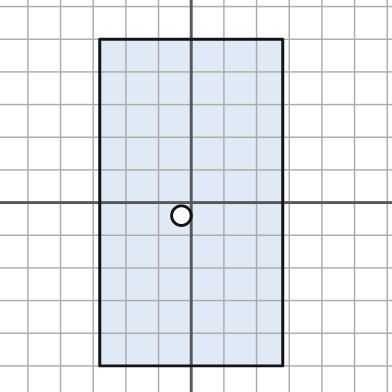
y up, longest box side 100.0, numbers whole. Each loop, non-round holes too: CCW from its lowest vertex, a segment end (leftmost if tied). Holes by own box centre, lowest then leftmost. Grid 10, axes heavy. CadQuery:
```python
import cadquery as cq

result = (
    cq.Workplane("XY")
    .moveTo(-28.0, -50.0)
    .lineTo(28.0, -50.0)
    .lineTo(28.0, 50.0)
    .lineTo(-28.0, 50.0)
    .close()
    .moveTo(-3.0, -4.0)
    .circle(3.0)
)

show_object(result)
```